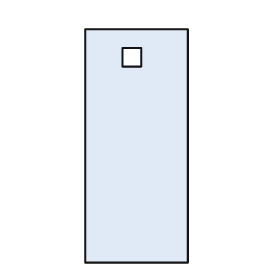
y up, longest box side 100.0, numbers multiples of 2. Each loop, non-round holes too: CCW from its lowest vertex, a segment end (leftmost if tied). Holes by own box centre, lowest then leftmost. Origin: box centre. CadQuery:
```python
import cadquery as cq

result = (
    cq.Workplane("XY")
    .moveTo(-22.0, -50.0)
    .lineTo(22.0, -50.0)
    .lineTo(22.0, 50.0)
    .lineTo(-22.0, 50.0)
    .close()
    .moveTo(-6.0, 34.0)
    .lineTo(2.0, 34.0)
    .lineTo(2.0, 42.0)
    .lineTo(-6.0, 42.0)
    .close()
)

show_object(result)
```